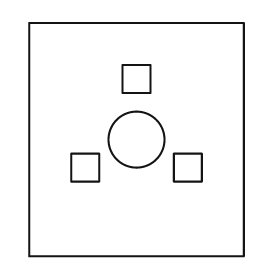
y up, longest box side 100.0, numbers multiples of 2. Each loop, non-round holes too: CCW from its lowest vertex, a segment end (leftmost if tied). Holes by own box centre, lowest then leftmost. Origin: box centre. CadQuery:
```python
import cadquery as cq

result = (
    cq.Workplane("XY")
    .moveTo(-46.0, -50.0)
    .lineTo(46.0, -50.0)
    .lineTo(46.0, 50.0)
    .lineTo(-46.0, 50.0)
    .close()
    .moveTo(-28.0, -18.0)
    .lineTo(-16.0, -18.0)
    .lineTo(-16.0, -6.0)
    .lineTo(-28.0, -6.0)
    .close()
    .moveTo(16.0, -18.0)
    .lineTo(28.0, -18.0)
    .lineTo(28.0, -6.0)
    .lineTo(16.0, -6.0)
    .close()
    .moveTo(0.0, 0.0)
    .circle(12.0)
    .moveTo(-6.0, 20.0)
    .lineTo(6.0, 20.0)
    .lineTo(6.0, 32.0)
    .lineTo(-6.0, 32.0)
    .close()
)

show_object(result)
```